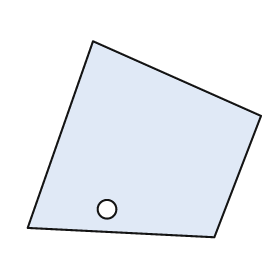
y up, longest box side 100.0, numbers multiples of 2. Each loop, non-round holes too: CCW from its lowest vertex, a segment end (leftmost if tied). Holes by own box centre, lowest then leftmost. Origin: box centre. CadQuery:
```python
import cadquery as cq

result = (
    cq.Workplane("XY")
    .moveTo(30.0, -42.0)
    .lineTo(50.0, 10.0)
    .lineTo(-22.0, 42.0)
    .lineTo(-50.0, -38.0)
    .close()
    .moveTo(-16.0, -30.0)
    .circle(4.0)
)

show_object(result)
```